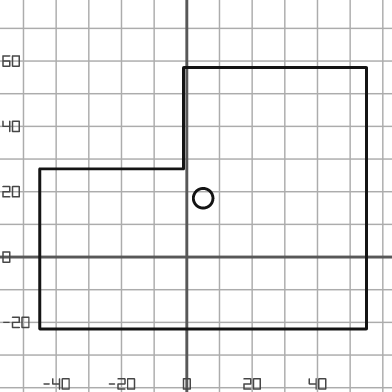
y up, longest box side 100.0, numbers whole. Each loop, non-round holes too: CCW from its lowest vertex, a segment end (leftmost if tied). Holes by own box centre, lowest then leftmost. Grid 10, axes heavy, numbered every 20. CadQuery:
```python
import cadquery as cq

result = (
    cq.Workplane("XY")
    .moveTo(-45.0, -22.0)
    .lineTo(55.0, -22.0)
    .lineTo(55.0, 58.0)
    .lineTo(-1.0, 58.0)
    .lineTo(-1.0, 27.0)
    .lineTo(-45.0, 27.0)
    .close()
    .moveTo(5.0, 18.0)
    .circle(3.0)
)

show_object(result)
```